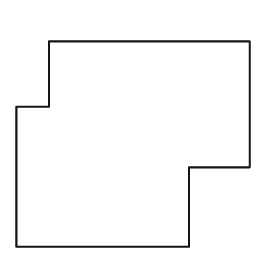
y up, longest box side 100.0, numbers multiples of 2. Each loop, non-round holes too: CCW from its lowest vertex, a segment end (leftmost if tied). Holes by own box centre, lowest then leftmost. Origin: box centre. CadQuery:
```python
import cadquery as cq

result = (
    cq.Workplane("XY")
    .moveTo(-50.0, -44.0)
    .lineTo(24.0, -44.0)
    .lineTo(24.0, -10.0)
    .lineTo(50.0, -10.0)
    .lineTo(50.0, 44.0)
    .lineTo(-36.0, 44.0)
    .lineTo(-36.0, 16.0)
    .lineTo(-50.0, 16.0)
    .close()
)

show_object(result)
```